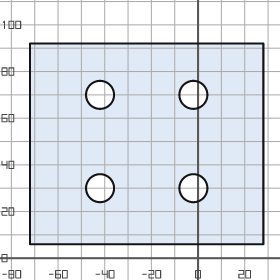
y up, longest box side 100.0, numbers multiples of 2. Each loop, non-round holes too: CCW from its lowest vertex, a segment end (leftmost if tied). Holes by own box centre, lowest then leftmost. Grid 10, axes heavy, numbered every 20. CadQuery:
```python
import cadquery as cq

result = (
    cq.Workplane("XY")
    .moveTo(-72.0, 6.0)
    .lineTo(28.0, 6.0)
    .lineTo(28.0, 92.0)
    .lineTo(-72.0, 92.0)
    .close()
    .moveTo(-42.0, 30.0)
    .circle(6.0)
    .moveTo(-2.0, 30.0)
    .circle(6.0)
    .moveTo(-42.0, 70.0)
    .circle(6.0)
    .moveTo(-2.0, 70.0)
    .circle(6.0)
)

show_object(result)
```